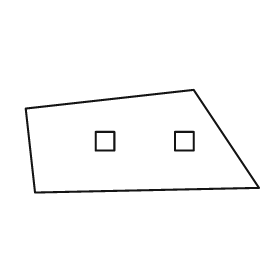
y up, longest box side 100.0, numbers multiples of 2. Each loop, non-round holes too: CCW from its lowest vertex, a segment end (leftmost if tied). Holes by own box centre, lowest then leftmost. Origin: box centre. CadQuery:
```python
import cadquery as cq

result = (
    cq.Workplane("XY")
    .moveTo(-46.0, -22.0)
    .lineTo(50.0, -20.0)
    .lineTo(22.0, 22.0)
    .lineTo(-50.0, 14.0)
    .close()
    .moveTo(-20.0, -4.0)
    .lineTo(-12.0, -4.0)
    .lineTo(-12.0, 4.0)
    .lineTo(-20.0, 4.0)
    .close()
    .moveTo(14.0, -4.0)
    .lineTo(22.0, -4.0)
    .lineTo(22.0, 4.0)
    .lineTo(14.0, 4.0)
    .close()
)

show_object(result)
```